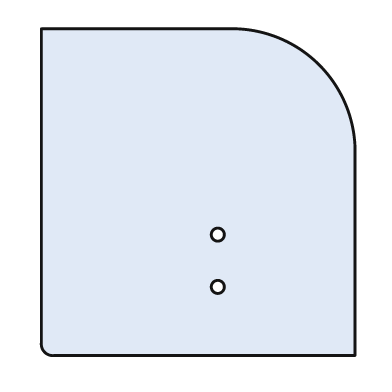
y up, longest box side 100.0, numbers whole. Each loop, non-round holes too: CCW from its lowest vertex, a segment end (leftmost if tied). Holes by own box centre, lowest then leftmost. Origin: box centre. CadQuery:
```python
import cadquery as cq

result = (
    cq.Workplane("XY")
    .moveTo(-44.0, -50.0)
    .lineTo(48.0, -50.0)
    .lineTo(48.0, 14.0)
    .threePointArc((37.0, 39.0), (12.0, 50.0))
    .lineTo(-48.0, 50.0)
    .lineTo(-48.0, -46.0)
    .threePointArc((-47.0, -49.0), (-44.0, -50.0))
    .close()
    .moveTo(6.0, -29.0)
    .circle(2.0)
    .moveTo(6.0, -13.0)
    .circle(2.0)
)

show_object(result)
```